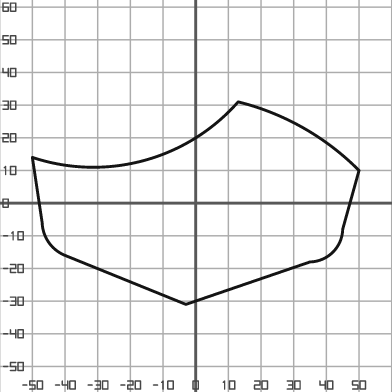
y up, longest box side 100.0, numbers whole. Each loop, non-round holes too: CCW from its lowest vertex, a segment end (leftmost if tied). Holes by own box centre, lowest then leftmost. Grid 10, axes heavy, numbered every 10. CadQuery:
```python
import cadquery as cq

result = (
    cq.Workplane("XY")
    .moveTo(-3.0, -31.0)
    .lineTo(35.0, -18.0)
    .threePointArc((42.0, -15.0), (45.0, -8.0))
    .lineTo(50.0, 10.0)
    .threePointArc((33.0, 23.0), (13.0, 31.0))
    .threePointArc((-16.0, 13.0), (-50.0, 14.0))
    .lineTo(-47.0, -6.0)
    .threePointArc((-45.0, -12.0), (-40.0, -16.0))
    .close()
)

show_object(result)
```